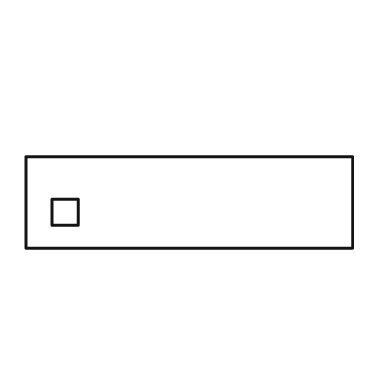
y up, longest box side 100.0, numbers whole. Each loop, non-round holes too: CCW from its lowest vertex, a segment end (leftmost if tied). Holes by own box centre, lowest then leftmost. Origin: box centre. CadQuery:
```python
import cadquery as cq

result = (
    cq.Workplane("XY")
    .moveTo(-50.0, -14.0)
    .lineTo(50.0, -14.0)
    .lineTo(50.0, 14.0)
    .lineTo(-50.0, 14.0)
    .close()
    .moveTo(-42.0, -7.0)
    .lineTo(-34.0, -7.0)
    .lineTo(-34.0, 1.0)
    .lineTo(-42.0, 1.0)
    .close()
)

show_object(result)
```